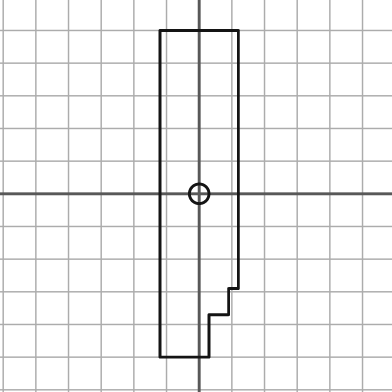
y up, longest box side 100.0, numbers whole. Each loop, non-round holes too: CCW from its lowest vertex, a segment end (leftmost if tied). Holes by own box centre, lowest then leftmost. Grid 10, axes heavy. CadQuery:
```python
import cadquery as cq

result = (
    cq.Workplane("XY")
    .moveTo(-12.0, -50.0)
    .lineTo(3.0, -50.0)
    .lineTo(3.0, -37.0)
    .lineTo(9.0, -37.0)
    .lineTo(9.0, -29.0)
    .lineTo(12.0, -29.0)
    .lineTo(12.0, 50.0)
    .lineTo(-12.0, 50.0)
    .close()
    .moveTo(0.0, 0.0)
    .circle(3.0)
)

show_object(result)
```